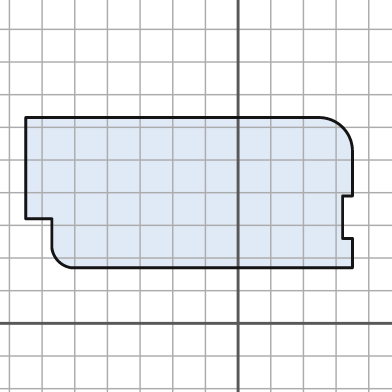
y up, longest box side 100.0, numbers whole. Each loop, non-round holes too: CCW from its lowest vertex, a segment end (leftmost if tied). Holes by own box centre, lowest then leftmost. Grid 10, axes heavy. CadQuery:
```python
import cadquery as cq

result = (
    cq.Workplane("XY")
    .moveTo(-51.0, 17.0)
    .lineTo(35.0, 17.0)
    .lineTo(35.0, 26.0)
    .lineTo(32.0, 26.0)
    .lineTo(32.0, 39.0)
    .lineTo(35.0, 39.0)
    .lineTo(35.0, 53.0)
    .threePointArc((32.0, 60.0), (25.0, 63.0))
    .lineTo(-65.0, 63.0)
    .lineTo(-65.0, 32.0)
    .lineTo(-57.0, 32.0)
    .lineTo(-57.0, 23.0)
    .threePointArc((-55.0, 19.0), (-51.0, 17.0))
    .close()
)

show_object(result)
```